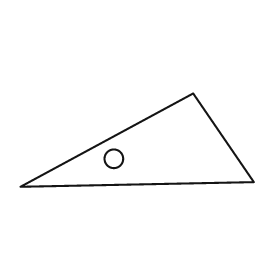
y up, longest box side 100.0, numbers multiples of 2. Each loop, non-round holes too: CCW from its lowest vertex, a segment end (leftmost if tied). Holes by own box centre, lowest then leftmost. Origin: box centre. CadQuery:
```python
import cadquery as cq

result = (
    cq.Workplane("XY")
    .moveTo(-50.0, -20.0)
    .lineTo(50.0, -18.0)
    .lineTo(24.0, 20.0)
    .close()
    .moveTo(-10.0, -8.0)
    .circle(4.0)
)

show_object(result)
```